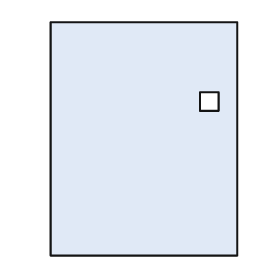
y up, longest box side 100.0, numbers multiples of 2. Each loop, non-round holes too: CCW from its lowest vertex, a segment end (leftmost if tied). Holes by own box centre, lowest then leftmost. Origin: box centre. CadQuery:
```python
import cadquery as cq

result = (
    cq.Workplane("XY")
    .moveTo(-40.0, -50.0)
    .lineTo(40.0, -50.0)
    .lineTo(40.0, 50.0)
    .lineTo(-40.0, 50.0)
    .close()
    .moveTo(24.0, 12.0)
    .lineTo(32.0, 12.0)
    .lineTo(32.0, 20.0)
    .lineTo(24.0, 20.0)
    .close()
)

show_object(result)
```